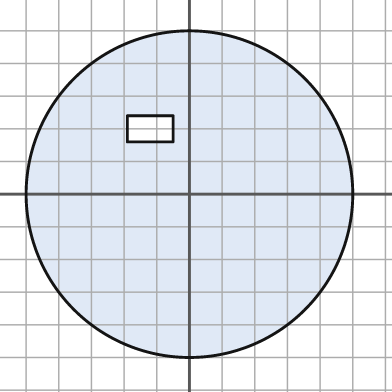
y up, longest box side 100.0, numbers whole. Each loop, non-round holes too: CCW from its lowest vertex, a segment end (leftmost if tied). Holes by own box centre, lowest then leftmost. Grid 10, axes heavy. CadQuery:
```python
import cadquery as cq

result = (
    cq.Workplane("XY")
    .moveTo(0.0, 0.0)
    .circle(50.0)
    .moveTo(-19.0, 16.0)
    .lineTo(-5.0, 16.0)
    .lineTo(-5.0, 24.0)
    .lineTo(-19.0, 24.0)
    .close()
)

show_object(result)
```